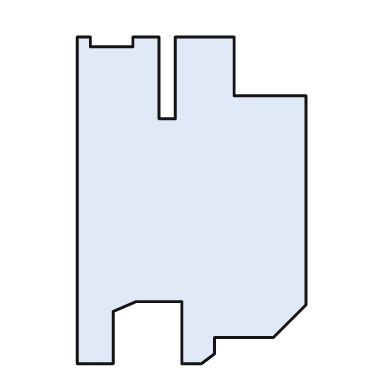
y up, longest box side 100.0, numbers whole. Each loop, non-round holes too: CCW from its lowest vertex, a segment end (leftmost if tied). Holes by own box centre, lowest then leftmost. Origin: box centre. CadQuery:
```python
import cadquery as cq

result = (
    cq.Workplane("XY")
    .moveTo(-35.0, -50.0)
    .lineTo(-24.0, -50.0)
    .lineTo(-24.0, -34.0)
    .lineTo(-17.0, -31.0)
    .lineTo(-3.0, -31.0)
    .lineTo(-3.0, -50.0)
    .lineTo(3.0, -50.0)
    .lineTo(7.0, -47.0)
    .lineTo(7.0, -42.0)
    .lineTo(25.0, -42.0)
    .lineTo(35.0, -32.0)
    .lineTo(35.0, 32.0)
    .lineTo(13.0, 32.0)
    .lineTo(13.0, 50.0)
    .lineTo(-5.0, 50.0)
    .lineTo(-5.0, 25.0)
    .lineTo(-10.0, 25.0)
    .lineTo(-10.0, 50.0)
    .lineTo(-18.0, 50.0)
    .lineTo(-18.0, 47.0)
    .lineTo(-31.0, 47.0)
    .lineTo(-31.0, 50.0)
    .lineTo(-35.0, 50.0)
    .close()
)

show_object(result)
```